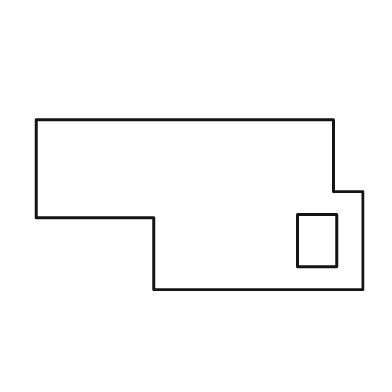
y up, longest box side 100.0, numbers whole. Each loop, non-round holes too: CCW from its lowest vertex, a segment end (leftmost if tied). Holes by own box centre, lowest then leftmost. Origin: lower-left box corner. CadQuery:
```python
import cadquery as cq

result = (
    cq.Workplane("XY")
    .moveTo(36.0, 0.0)
    .lineTo(100.0, 0.0)
    .lineTo(100.0, 30.0)
    .lineTo(91.0, 30.0)
    .lineTo(91.0, 52.0)
    .lineTo(0.0, 52.0)
    .lineTo(0.0, 22.0)
    .lineTo(36.0, 22.0)
    .close()
    .moveTo(80.0, 7.0)
    .lineTo(92.0, 7.0)
    .lineTo(92.0, 23.0)
    .lineTo(80.0, 23.0)
    .close()
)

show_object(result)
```